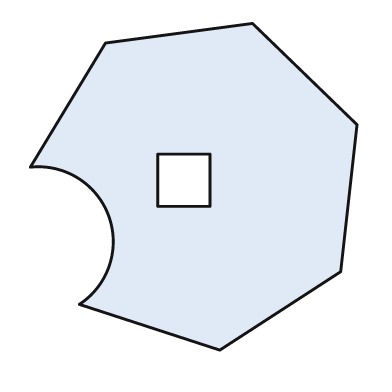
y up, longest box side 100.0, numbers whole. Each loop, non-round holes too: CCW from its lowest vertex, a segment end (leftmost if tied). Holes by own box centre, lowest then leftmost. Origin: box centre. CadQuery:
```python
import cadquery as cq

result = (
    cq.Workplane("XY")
    .moveTo(8.0, -50.0)
    .lineTo(45.0, -26.0)
    .lineTo(50.0, 19.0)
    .lineTo(18.0, 50.0)
    .lineTo(-27.0, 44.0)
    .lineTo(-50.0, 6.0)
    .threePointArc((-26.0, -9.0), (-35.0, -36.0))
    .close()
    .moveTo(-11.0, -6.0)
    .lineTo(5.0, -6.0)
    .lineTo(5.0, 10.0)
    .lineTo(-11.0, 10.0)
    .close()
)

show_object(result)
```